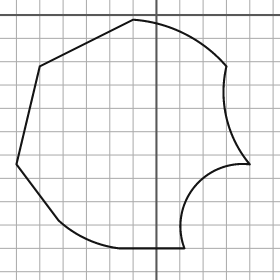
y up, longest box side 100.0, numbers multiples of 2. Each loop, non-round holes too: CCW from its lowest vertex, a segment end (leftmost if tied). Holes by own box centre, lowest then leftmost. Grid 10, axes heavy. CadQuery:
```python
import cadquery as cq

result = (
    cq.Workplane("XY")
    .moveTo(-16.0, -100.0)
    .lineTo(12.0, -100.0)
    .threePointArc((16.0, -74.0), (40.0, -64.0))
    .threePointArc((30.0, -44.0), (30.0, -22.0))
    .threePointArc((12.0, -8.0), (-10.0, -2.0))
    .lineTo(-50.0, -22.0)
    .lineTo(-60.0, -64.0)
    .lineTo(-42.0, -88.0)
    .threePointArc((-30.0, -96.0), (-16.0, -100.0))
    .close()
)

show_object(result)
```